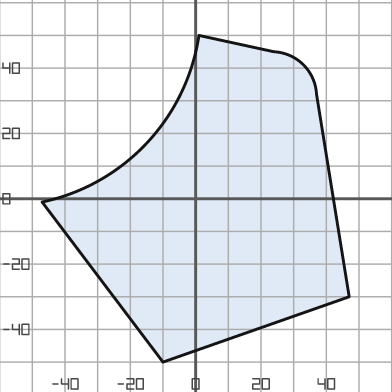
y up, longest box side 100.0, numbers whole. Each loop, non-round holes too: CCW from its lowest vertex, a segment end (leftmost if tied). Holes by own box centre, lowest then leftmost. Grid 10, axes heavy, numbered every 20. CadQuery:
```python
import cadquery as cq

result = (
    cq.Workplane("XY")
    .moveTo(-10.0, -50.0)
    .lineTo(47.0, -30.0)
    .lineTo(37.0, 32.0)
    .threePointArc((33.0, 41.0), (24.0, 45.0))
    .lineTo(1.0, 50.0)
    .threePointArc((-15.0, 17.0), (-47.0, -1.0))
    .close()
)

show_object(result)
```